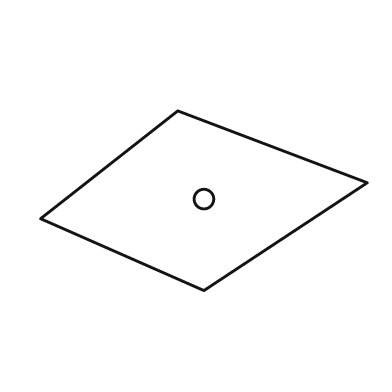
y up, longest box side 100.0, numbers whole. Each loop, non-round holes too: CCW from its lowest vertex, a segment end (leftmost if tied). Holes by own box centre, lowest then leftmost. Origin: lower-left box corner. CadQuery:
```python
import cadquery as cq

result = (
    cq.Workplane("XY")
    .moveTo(50.0, 0.0)
    .lineTo(100.0, 33.0)
    .lineTo(42.0, 55.0)
    .lineTo(0.0, 22.0)
    .close()
    .moveTo(50.0, 28.0)
    .circle(3.0)
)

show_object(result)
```